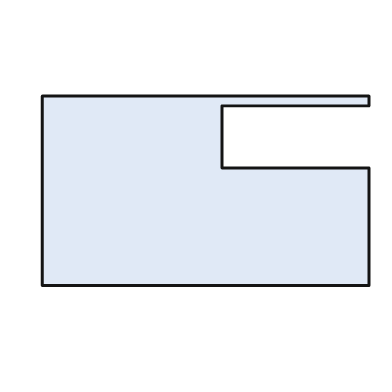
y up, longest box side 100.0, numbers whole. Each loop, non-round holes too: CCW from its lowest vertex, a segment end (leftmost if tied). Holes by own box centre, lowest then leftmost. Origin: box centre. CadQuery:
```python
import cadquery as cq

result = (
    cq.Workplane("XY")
    .moveTo(-50.0, -29.0)
    .lineTo(50.0, -29.0)
    .lineTo(50.0, 7.0)
    .lineTo(5.0, 7.0)
    .lineTo(5.0, 26.0)
    .lineTo(50.0, 26.0)
    .lineTo(50.0, 29.0)
    .lineTo(-50.0, 29.0)
    .close()
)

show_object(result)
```